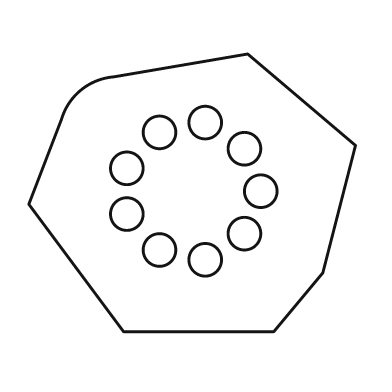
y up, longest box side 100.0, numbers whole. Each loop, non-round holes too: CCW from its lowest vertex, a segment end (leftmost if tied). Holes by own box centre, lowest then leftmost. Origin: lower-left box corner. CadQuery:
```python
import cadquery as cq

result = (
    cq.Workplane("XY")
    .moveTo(29.0, 0.0)
    .lineTo(75.0, 0.0)
    .lineTo(90.0, 18.0)
    .lineTo(100.0, 57.0)
    .lineTo(67.0, 85.0)
    .lineTo(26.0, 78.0)
    .threePointArc((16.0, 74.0), (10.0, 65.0))
    .lineTo(0.0, 39.0)
    .close()
    .moveTo(54.0, 22.0)
    .circle(5.0)
    .moveTo(40.0, 25.0)
    .circle(5.0)
    .moveTo(66.0, 30.0)
    .circle(5.0)
    .moveTo(30.0, 36.0)
    .circle(5.0)
    .moveTo(71.0, 43.0)
    .circle(5.0)
    .moveTo(30.0, 50.0)
    .circle(5.0)
    .moveTo(66.0, 56.0)
    .circle(5.0)
    .moveTo(40.0, 61.0)
    .circle(5.0)
    .moveTo(54.0, 64.0)
    .circle(5.0)
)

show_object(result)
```